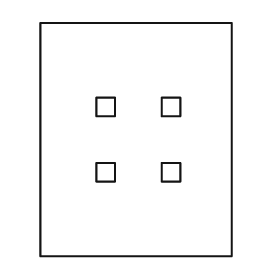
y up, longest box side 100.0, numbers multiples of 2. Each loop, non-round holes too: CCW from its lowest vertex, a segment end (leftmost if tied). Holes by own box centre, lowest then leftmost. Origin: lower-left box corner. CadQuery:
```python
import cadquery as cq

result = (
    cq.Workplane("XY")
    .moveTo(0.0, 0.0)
    .lineTo(82.0, 0.0)
    .lineTo(82.0, 100.0)
    .lineTo(0.0, 100.0)
    .close()
    .moveTo(24.0, 32.0)
    .lineTo(32.0, 32.0)
    .lineTo(32.0, 40.0)
    .lineTo(24.0, 40.0)
    .close()
    .moveTo(52.0, 32.0)
    .lineTo(60.0, 32.0)
    .lineTo(60.0, 40.0)
    .lineTo(52.0, 40.0)
    .close()
    .moveTo(24.0, 60.0)
    .lineTo(32.0, 60.0)
    .lineTo(32.0, 68.0)
    .lineTo(24.0, 68.0)
    .close()
    .moveTo(52.0, 60.0)
    .lineTo(60.0, 60.0)
    .lineTo(60.0, 68.0)
    .lineTo(52.0, 68.0)
    .close()
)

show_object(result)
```